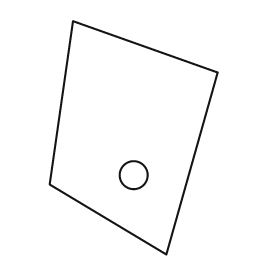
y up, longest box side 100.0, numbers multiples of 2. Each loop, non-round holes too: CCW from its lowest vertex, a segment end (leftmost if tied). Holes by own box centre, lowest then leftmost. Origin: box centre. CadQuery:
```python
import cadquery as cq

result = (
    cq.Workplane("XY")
    .moveTo(14.0, -50.0)
    .lineTo(36.0, 28.0)
    .lineTo(-26.0, 50.0)
    .lineTo(-36.0, -20.0)
    .close()
    .moveTo(0.0, -16.0)
    .circle(6.0)
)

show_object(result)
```